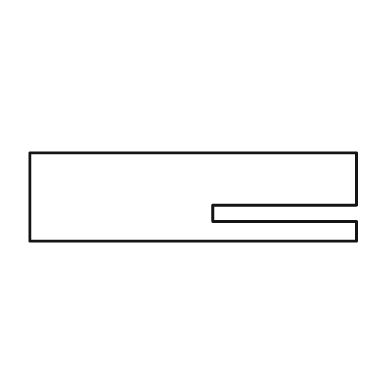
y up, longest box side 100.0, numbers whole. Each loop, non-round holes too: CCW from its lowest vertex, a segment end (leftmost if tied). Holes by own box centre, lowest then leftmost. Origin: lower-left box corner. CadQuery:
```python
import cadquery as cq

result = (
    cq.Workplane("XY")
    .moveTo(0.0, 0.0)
    .lineTo(100.0, 0.0)
    .lineTo(100.0, 6.0)
    .lineTo(56.0, 6.0)
    .lineTo(56.0, 11.0)
    .lineTo(100.0, 11.0)
    .lineTo(100.0, 27.0)
    .lineTo(0.0, 27.0)
    .close()
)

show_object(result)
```